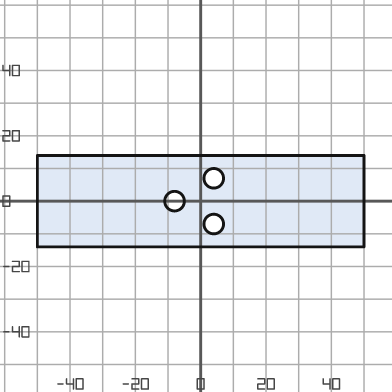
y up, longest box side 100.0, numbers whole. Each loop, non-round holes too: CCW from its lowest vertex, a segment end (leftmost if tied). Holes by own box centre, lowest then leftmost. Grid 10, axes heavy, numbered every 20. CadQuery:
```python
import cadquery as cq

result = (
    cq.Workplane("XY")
    .moveTo(-50.0, -14.0)
    .lineTo(50.0, -14.0)
    .lineTo(50.0, 14.0)
    .lineTo(-50.0, 14.0)
    .close()
    .moveTo(4.0, -7.0)
    .circle(3.0)
    .moveTo(-8.0, 0.0)
    .circle(3.0)
    .moveTo(4.0, 7.0)
    .circle(3.0)
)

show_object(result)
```